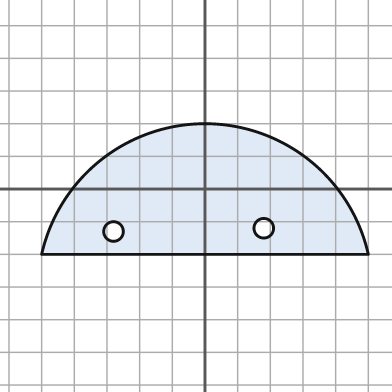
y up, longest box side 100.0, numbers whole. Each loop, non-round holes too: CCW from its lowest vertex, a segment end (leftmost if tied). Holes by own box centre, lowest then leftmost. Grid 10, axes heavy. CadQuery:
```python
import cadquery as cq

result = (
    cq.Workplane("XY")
    .moveTo(-50.0, -20.0)
    .lineTo(50.0, -20.0)
    .threePointArc((0.0, 20.0), (-50.0, -20.0))
    .close()
    .moveTo(-28.0, -13.0)
    .circle(3.0)
    .moveTo(18.0, -12.0)
    .circle(3.0)
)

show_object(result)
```